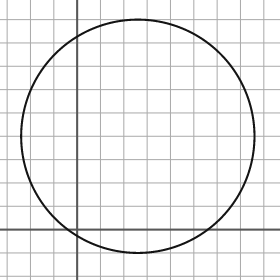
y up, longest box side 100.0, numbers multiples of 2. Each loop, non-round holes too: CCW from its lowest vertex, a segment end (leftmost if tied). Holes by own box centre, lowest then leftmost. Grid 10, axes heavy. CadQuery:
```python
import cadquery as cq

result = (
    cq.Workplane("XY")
    .moveTo(26.0, 40.0)
    .circle(50.0)
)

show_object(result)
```